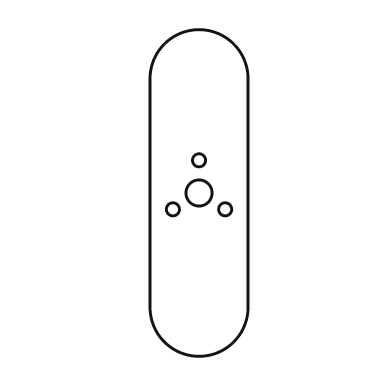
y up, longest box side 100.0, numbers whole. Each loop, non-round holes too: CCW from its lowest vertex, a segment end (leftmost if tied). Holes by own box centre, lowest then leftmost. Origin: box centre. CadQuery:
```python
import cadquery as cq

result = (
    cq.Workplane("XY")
    .moveTo(-15.0, -35.0)
    .threePointArc((0.0, -50.0), (15.0, -35.0))
    .lineTo(15.0, 35.0)
    .threePointArc((0.0, 50.0), (-15.0, 35.0))
    .close()
    .moveTo(-8.0, -5.0)
    .circle(2.0)
    .moveTo(8.0, -5.0)
    .circle(2.0)
    .moveTo(0.0, 0.0)
    .circle(4.0)
    .moveTo(0.0, 10.0)
    .circle(2.0)
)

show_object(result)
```